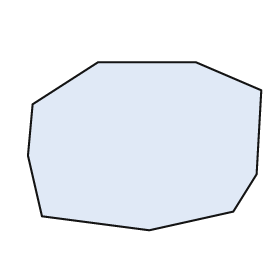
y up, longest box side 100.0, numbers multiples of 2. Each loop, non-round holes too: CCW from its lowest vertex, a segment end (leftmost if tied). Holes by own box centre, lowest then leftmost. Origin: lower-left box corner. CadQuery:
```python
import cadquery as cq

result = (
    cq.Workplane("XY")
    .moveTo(52.0, 0.0)
    .lineTo(88.0, 8.0)
    .lineTo(98.0, 24.0)
    .lineTo(100.0, 60.0)
    .lineTo(72.0, 72.0)
    .lineTo(30.0, 72.0)
    .lineTo(2.0, 54.0)
    .lineTo(0.0, 32.0)
    .lineTo(6.0, 6.0)
    .close()
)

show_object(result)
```